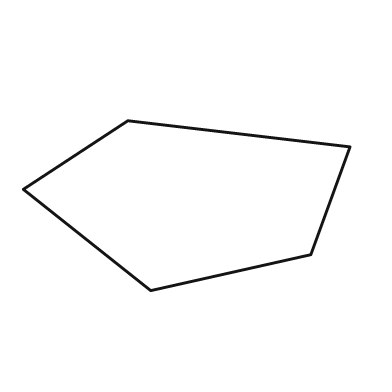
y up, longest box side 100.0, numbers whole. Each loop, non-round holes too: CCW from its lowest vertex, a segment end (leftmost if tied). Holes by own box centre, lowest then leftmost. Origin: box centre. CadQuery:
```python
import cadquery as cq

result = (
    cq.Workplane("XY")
    .moveTo(-11.0, -26.0)
    .lineTo(38.0, -15.0)
    .lineTo(50.0, 18.0)
    .lineTo(-18.0, 26.0)
    .lineTo(-50.0, 5.0)
    .close()
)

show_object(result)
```